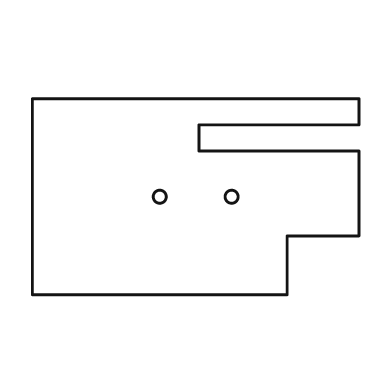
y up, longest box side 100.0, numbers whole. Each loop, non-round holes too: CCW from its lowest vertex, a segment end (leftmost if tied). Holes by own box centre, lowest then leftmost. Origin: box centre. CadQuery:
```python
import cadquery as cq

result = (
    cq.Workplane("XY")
    .moveTo(-50.0, -30.0)
    .lineTo(28.0, -30.0)
    .lineTo(28.0, -12.0)
    .lineTo(50.0, -12.0)
    .lineTo(50.0, 14.0)
    .lineTo(1.0, 14.0)
    .lineTo(1.0, 22.0)
    .lineTo(50.0, 22.0)
    .lineTo(50.0, 30.0)
    .lineTo(-50.0, 30.0)
    .close()
    .moveTo(-11.0, 0.0)
    .circle(2.0)
    .moveTo(11.0, 0.0)
    .circle(2.0)
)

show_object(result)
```